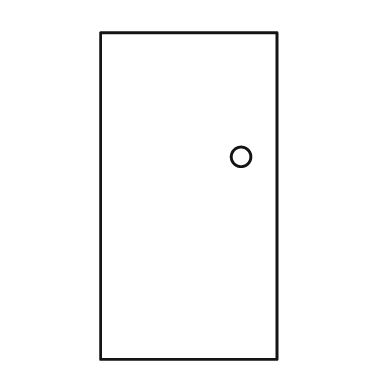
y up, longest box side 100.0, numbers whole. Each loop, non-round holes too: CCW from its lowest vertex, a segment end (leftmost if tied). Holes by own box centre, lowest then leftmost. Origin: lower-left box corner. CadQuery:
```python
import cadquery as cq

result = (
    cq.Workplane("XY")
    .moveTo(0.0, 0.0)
    .lineTo(54.0, 0.0)
    .lineTo(54.0, 100.0)
    .lineTo(0.0, 100.0)
    .close()
    .moveTo(43.0, 62.0)
    .circle(3.0)
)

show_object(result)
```